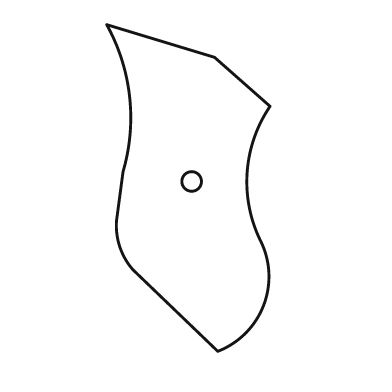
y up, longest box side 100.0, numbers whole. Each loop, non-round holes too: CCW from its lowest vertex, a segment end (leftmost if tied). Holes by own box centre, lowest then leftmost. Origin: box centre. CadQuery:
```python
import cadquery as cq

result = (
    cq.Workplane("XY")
    .moveTo(9.0, -50.0)
    .threePointArc((23.0, -36.0), (22.0, -16.0))
    .threePointArc((18.0, 5.0), (25.0, 25.0))
    .lineTo(8.0, 40.0)
    .lineTo(-25.0, 50.0)
    .threePointArc((-18.0, 28.0), (-20.0, 5.0))
    .lineTo(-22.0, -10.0)
    .threePointArc((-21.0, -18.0), (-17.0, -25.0))
    .close()
    .moveTo(1.0, 2.0)
    .circle(3.0)
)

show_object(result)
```